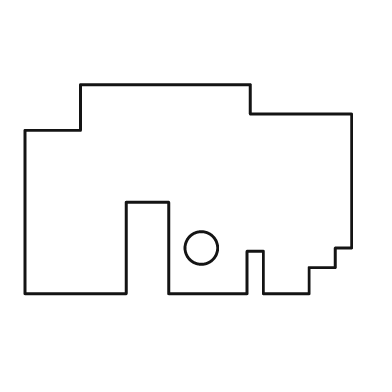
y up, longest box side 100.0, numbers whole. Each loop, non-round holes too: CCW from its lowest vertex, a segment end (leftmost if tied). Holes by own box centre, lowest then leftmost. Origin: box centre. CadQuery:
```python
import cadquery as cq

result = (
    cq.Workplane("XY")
    .moveTo(-50.0, -32.0)
    .lineTo(-19.0, -32.0)
    .lineTo(-19.0, -4.0)
    .lineTo(-6.0, -4.0)
    .lineTo(-6.0, -32.0)
    .lineTo(18.0, -32.0)
    .lineTo(18.0, -19.0)
    .lineTo(23.0, -19.0)
    .lineTo(23.0, -32.0)
    .lineTo(37.0, -32.0)
    .lineTo(37.0, -24.0)
    .lineTo(45.0, -24.0)
    .lineTo(45.0, -18.0)
    .lineTo(50.0, -18.0)
    .lineTo(50.0, 23.0)
    .lineTo(19.0, 23.0)
    .lineTo(19.0, 32.0)
    .lineTo(-33.0, 32.0)
    .lineTo(-33.0, 18.0)
    .lineTo(-50.0, 18.0)
    .close()
    .moveTo(4.0, -18.0)
    .circle(5.0)
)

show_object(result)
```